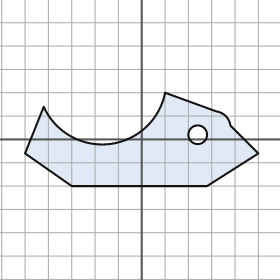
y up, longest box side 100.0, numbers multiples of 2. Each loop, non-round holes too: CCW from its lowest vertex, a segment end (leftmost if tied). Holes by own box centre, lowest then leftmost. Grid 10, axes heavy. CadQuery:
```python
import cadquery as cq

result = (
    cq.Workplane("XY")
    .moveTo(-30.0, -20.0)
    .lineTo(28.0, -20.0)
    .lineTo(50.0, -6.0)
    .lineTo(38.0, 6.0)
    .threePointArc((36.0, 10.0), (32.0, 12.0))
    .lineTo(10.0, 20.0)
    .threePointArc((-14.0, -2.0), (-42.0, 14.0))
    .lineTo(-50.0, -6.0)
    .close()
    .moveTo(24.0, 2.0)
    .circle(4.0)
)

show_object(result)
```